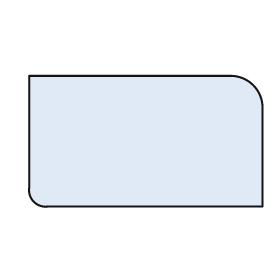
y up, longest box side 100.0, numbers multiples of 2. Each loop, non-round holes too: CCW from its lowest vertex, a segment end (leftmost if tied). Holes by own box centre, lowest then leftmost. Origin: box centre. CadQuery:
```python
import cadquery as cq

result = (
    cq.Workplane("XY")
    .moveTo(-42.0, -28.0)
    .lineTo(50.0, -28.0)
    .lineTo(50.0, 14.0)
    .threePointArc((46.0, 24.0), (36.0, 28.0))
    .lineTo(-50.0, 28.0)
    .lineTo(-50.0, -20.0)
    .threePointArc((-48.0, -26.0), (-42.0, -28.0))
    .close()
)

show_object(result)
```